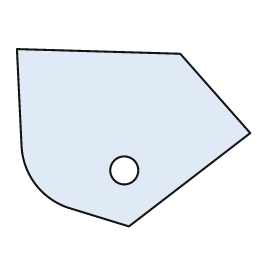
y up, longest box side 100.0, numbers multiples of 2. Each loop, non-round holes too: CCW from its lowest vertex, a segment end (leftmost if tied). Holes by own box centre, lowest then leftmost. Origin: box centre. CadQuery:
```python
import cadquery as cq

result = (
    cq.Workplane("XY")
    .moveTo(-2.0, -38.0)
    .lineTo(50.0, 2.0)
    .lineTo(20.0, 36.0)
    .lineTo(-50.0, 38.0)
    .lineTo(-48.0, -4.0)
    .threePointArc((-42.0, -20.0), (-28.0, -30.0))
    .close()
    .moveTo(-4.0, -14.0)
    .circle(6.0)
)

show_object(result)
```